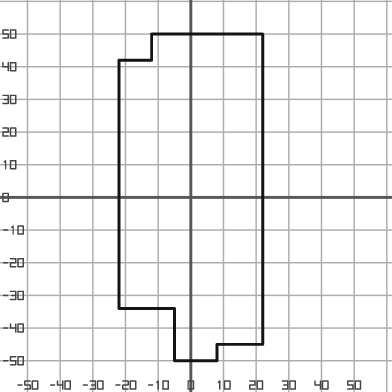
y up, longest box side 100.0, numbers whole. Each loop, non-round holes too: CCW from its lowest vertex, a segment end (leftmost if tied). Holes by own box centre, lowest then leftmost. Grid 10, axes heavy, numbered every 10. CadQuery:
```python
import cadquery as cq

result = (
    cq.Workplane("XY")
    .moveTo(-5.0, -50.0)
    .lineTo(8.0, -50.0)
    .lineTo(8.0, -45.0)
    .lineTo(22.0, -45.0)
    .lineTo(22.0, 50.0)
    .lineTo(-12.0, 50.0)
    .lineTo(-12.0, 42.0)
    .lineTo(-22.0, 42.0)
    .lineTo(-22.0, -34.0)
    .lineTo(-5.0, -34.0)
    .close()
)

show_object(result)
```